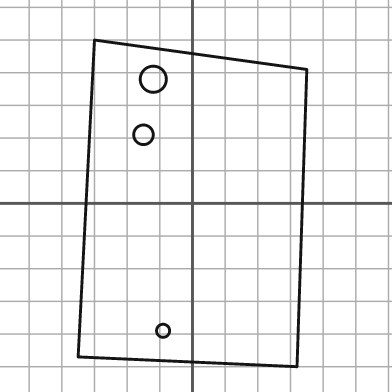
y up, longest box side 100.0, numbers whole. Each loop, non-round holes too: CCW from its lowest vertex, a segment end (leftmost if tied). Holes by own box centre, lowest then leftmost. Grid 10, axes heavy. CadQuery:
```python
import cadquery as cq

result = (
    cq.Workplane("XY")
    .moveTo(32.0, -50.0)
    .lineTo(35.0, 41.0)
    .lineTo(-30.0, 50.0)
    .lineTo(-35.0, -47.0)
    .close()
    .moveTo(-9.0, -39.0)
    .circle(2.0)
    .moveTo(-15.0, 21.0)
    .circle(3.0)
    .moveTo(-12.0, 38.0)
    .circle(4.0)
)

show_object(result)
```